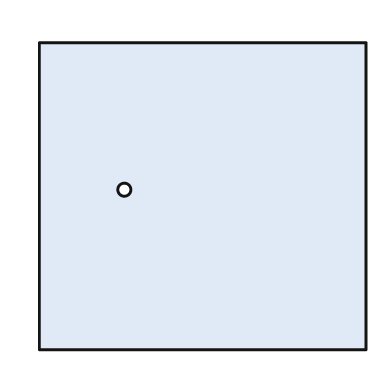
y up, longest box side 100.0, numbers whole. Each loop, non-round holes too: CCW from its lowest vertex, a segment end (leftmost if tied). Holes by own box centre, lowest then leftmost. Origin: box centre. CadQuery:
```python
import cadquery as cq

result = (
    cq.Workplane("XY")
    .moveTo(-50.0, -47.0)
    .lineTo(50.0, -47.0)
    .lineTo(50.0, 47.0)
    .lineTo(-50.0, 47.0)
    .close()
    .moveTo(-24.0, 2.0)
    .circle(2.0)
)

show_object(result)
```